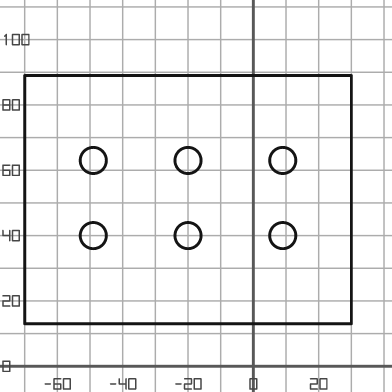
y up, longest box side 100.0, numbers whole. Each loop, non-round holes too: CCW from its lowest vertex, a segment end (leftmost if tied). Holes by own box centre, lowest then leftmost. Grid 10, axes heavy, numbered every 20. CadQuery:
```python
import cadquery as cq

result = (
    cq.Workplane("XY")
    .moveTo(-70.0, 13.0)
    .lineTo(30.0, 13.0)
    .lineTo(30.0, 89.0)
    .lineTo(-70.0, 89.0)
    .close()
    .moveTo(-49.0, 40.0)
    .circle(4.0)
    .moveTo(-20.0, 40.0)
    .circle(4.0)
    .moveTo(9.0, 40.0)
    .circle(4.0)
    .moveTo(-49.0, 63.0)
    .circle(4.0)
    .moveTo(-20.0, 63.0)
    .circle(4.0)
    .moveTo(9.0, 63.0)
    .circle(4.0)
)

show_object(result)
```